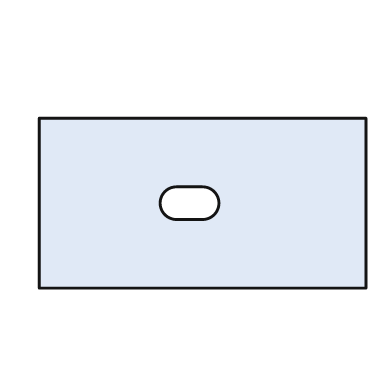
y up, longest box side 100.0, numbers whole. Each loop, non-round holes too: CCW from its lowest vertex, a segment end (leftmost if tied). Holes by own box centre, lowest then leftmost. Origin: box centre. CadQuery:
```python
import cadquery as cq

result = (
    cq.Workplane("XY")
    .moveTo(-50.0, -26.0)
    .lineTo(50.0, -26.0)
    .lineTo(50.0, 26.0)
    .lineTo(-50.0, 26.0)
    .close()
    .moveTo(-8.0, -5.0)
    .lineTo(0.0, -5.0)
    .threePointArc((5.0, 0.0), (0.0, 5.0))
    .lineTo(-8.0, 5.0)
    .threePointArc((-13.0, 0.0), (-8.0, -5.0))
    .close()
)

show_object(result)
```